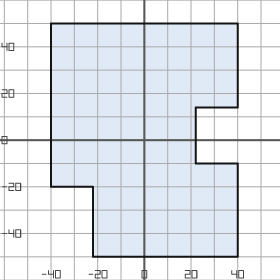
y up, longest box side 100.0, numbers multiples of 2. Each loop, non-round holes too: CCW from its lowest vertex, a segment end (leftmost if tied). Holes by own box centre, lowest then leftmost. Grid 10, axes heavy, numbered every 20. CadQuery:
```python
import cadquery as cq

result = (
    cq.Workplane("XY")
    .moveTo(-22.0, -50.0)
    .lineTo(40.0, -50.0)
    .lineTo(40.0, -10.0)
    .lineTo(22.0, -10.0)
    .lineTo(22.0, 14.0)
    .lineTo(40.0, 14.0)
    .lineTo(40.0, 50.0)
    .lineTo(-40.0, 50.0)
    .lineTo(-40.0, -20.0)
    .lineTo(-22.0, -20.0)
    .close()
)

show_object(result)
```